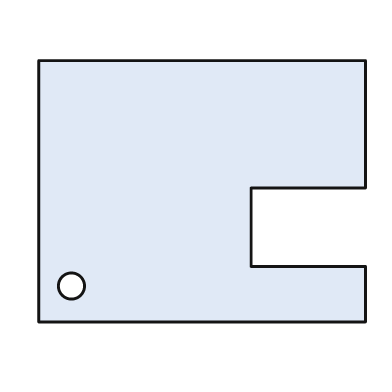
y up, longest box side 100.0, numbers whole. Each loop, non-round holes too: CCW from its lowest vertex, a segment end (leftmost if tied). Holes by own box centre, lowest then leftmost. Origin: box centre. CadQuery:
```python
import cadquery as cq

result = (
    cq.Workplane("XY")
    .moveTo(-50.0, -40.0)
    .lineTo(50.0, -40.0)
    .lineTo(50.0, -23.0)
    .lineTo(15.0, -23.0)
    .lineTo(15.0, 1.0)
    .lineTo(50.0, 1.0)
    .lineTo(50.0, 40.0)
    .lineTo(-50.0, 40.0)
    .close()
    .moveTo(-40.0, -29.0)
    .circle(4.0)
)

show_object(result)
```